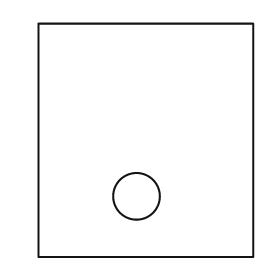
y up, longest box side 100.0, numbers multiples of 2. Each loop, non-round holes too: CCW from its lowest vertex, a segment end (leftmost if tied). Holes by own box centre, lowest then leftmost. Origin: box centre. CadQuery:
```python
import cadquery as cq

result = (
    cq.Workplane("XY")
    .moveTo(-46.0, -50.0)
    .lineTo(46.0, -50.0)
    .lineTo(46.0, 50.0)
    .lineTo(-46.0, 50.0)
    .close()
    .moveTo(-4.0, -24.0)
    .circle(10.0)
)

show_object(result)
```